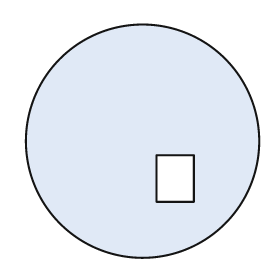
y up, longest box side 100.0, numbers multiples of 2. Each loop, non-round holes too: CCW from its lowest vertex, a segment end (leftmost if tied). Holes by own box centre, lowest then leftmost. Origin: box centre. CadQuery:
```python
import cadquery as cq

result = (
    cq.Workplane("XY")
    .moveTo(0.0, 0.0)
    .circle(50.0)
    .moveTo(6.0, -26.0)
    .lineTo(22.0, -26.0)
    .lineTo(22.0, -6.0)
    .lineTo(6.0, -6.0)
    .close()
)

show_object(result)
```